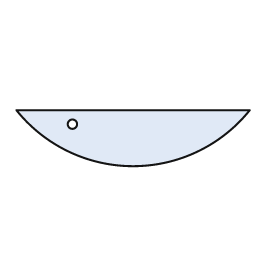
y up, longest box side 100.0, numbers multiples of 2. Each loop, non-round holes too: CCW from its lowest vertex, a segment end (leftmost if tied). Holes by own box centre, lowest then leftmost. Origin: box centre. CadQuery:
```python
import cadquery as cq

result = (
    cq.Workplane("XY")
    .moveTo(-50.0, 12.0)
    .threePointArc((0.0, -12.0), (50.0, 12.0))
    .close()
    .moveTo(-26.0, 6.0)
    .circle(2.0)
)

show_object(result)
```